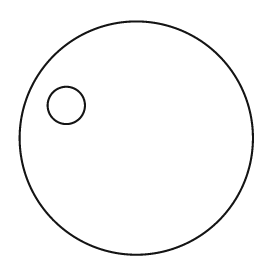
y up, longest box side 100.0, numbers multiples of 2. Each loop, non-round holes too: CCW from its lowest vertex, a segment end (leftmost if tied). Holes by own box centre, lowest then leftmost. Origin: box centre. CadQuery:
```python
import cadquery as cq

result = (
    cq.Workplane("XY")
    .moveTo(0.0, 0.0)
    .circle(50.0)
    .moveTo(-30.0, 14.0)
    .circle(8.0)
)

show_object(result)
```